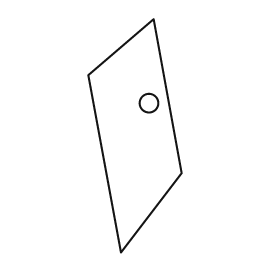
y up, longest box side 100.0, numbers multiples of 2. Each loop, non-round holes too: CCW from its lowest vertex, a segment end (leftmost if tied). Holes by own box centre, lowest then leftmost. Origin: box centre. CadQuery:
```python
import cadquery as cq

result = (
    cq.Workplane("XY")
    .moveTo(-6.0, -50.0)
    .lineTo(20.0, -16.0)
    .lineTo(8.0, 50.0)
    .lineTo(-20.0, 26.0)
    .close()
    .moveTo(6.0, 14.0)
    .circle(4.0)
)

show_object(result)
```